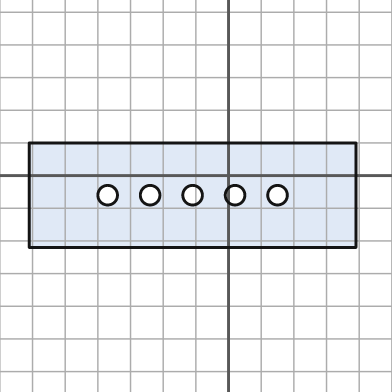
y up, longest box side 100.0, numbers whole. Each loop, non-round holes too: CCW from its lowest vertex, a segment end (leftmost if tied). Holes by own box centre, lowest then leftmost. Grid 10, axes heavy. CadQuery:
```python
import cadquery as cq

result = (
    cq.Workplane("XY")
    .moveTo(-61.0, -22.0)
    .lineTo(39.0, -22.0)
    .lineTo(39.0, 10.0)
    .lineTo(-61.0, 10.0)
    .close()
    .moveTo(-37.0, -6.0)
    .circle(3.0)
    .moveTo(-24.0, -6.0)
    .circle(3.0)
    .moveTo(-11.0, -6.0)
    .circle(3.0)
    .moveTo(2.0, -6.0)
    .circle(3.0)
    .moveTo(15.0, -6.0)
    .circle(3.0)
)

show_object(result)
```